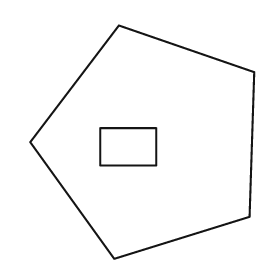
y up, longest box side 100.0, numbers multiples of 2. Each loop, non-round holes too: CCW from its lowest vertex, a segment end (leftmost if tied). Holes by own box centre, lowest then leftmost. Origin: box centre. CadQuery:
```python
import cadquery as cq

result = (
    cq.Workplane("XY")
    .moveTo(-12.0, -50.0)
    .lineTo(46.0, -32.0)
    .lineTo(48.0, 30.0)
    .lineTo(-10.0, 50.0)
    .lineTo(-48.0, 0.0)
    .close()
    .moveTo(-18.0, -10.0)
    .lineTo(6.0, -10.0)
    .lineTo(6.0, 6.0)
    .lineTo(-18.0, 6.0)
    .close()
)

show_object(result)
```